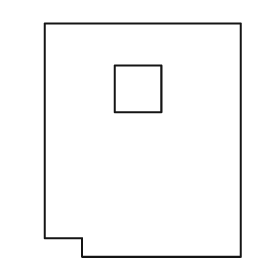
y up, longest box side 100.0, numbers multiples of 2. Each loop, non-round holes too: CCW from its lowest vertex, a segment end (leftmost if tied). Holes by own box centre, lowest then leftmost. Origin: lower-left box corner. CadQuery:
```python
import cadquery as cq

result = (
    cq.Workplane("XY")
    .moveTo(16.0, 0.0)
    .lineTo(84.0, 0.0)
    .lineTo(84.0, 100.0)
    .lineTo(0.0, 100.0)
    .lineTo(0.0, 8.0)
    .lineTo(16.0, 8.0)
    .close()
    .moveTo(30.0, 62.0)
    .lineTo(50.0, 62.0)
    .lineTo(50.0, 82.0)
    .lineTo(30.0, 82.0)
    .close()
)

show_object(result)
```